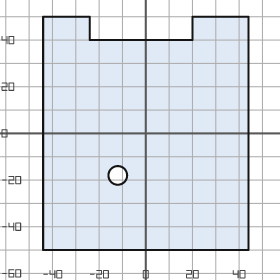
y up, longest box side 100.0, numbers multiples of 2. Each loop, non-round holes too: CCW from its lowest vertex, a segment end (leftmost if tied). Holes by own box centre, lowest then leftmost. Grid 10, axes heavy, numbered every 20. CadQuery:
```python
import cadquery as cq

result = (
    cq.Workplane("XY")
    .moveTo(-44.0, -50.0)
    .lineTo(44.0, -50.0)
    .lineTo(44.0, 50.0)
    .lineTo(20.0, 50.0)
    .lineTo(20.0, 40.0)
    .lineTo(-24.0, 40.0)
    .lineTo(-24.0, 50.0)
    .lineTo(-44.0, 50.0)
    .close()
    .moveTo(-12.0, -18.0)
    .circle(4.0)
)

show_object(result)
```